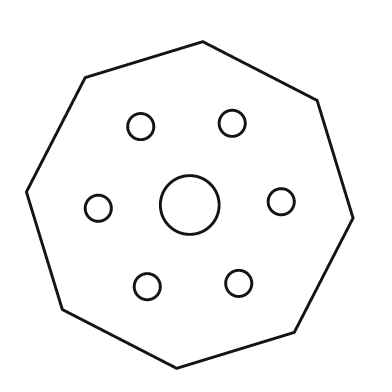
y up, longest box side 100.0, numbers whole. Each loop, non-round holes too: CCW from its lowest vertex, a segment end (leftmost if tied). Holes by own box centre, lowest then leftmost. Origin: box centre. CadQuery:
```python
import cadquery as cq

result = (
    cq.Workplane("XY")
    .moveTo(-4.0, -50.0)
    .lineTo(32.0, -39.0)
    .lineTo(50.0, -4.0)
    .lineTo(39.0, 32.0)
    .lineTo(4.0, 50.0)
    .lineTo(-32.0, 39.0)
    .lineTo(-50.0, 4.0)
    .lineTo(-39.0, -32.0)
    .close()
    .moveTo(-13.0, -25.0)
    .circle(4.0)
    .moveTo(15.0, -24.0)
    .circle(4.0)
    .moveTo(-28.0, -1.0)
    .circle(4.0)
    .moveTo(0.0, 0.0)
    .circle(9.0)
    .moveTo(28.0, 1.0)
    .circle(4.0)
    .moveTo(-15.0, 24.0)
    .circle(4.0)
    .moveTo(13.0, 25.0)
    .circle(4.0)
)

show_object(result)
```